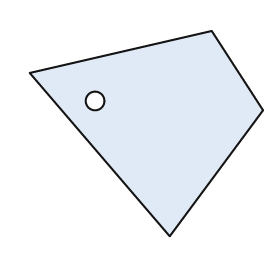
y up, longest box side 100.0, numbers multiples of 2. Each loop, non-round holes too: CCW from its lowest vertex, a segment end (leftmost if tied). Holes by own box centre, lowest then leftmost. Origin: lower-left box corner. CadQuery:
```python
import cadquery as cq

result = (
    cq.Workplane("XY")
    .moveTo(60.0, 0.0)
    .lineTo(100.0, 54.0)
    .lineTo(78.0, 88.0)
    .lineTo(0.0, 70.0)
    .close()
    .moveTo(28.0, 58.0)
    .circle(4.0)
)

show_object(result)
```